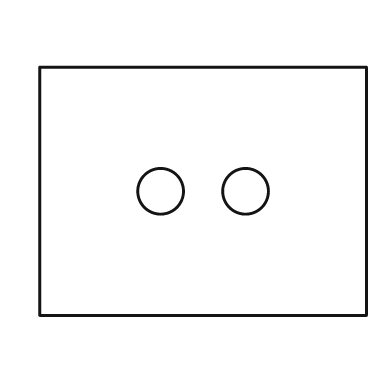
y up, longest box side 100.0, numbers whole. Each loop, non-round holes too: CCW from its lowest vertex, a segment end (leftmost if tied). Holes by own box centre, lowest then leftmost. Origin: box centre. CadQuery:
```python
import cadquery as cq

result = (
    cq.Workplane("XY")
    .moveTo(-50.0, -38.0)
    .lineTo(50.0, -38.0)
    .lineTo(50.0, 38.0)
    .lineTo(-50.0, 38.0)
    .close()
    .moveTo(-13.0, 0.0)
    .circle(7.0)
    .moveTo(13.0, 0.0)
    .circle(7.0)
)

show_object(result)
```